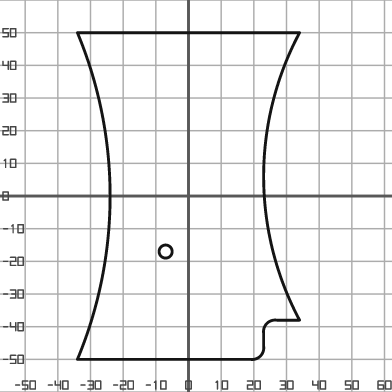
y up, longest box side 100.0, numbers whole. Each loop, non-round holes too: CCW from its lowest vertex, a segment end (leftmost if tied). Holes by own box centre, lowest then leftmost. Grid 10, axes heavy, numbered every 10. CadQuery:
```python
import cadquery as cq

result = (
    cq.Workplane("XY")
    .moveTo(-34.0, -50.0)
    .lineTo(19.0, -50.0)
    .threePointArc((22.0, -49.0), (23.0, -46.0))
    .lineTo(23.0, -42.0)
    .threePointArc((24.0, -39.0), (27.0, -38.0))
    .lineTo(34.0, -38.0)
    .threePointArc((23.0, 6.0), (34.0, 50.0))
    .lineTo(-34.0, 50.0)
    .threePointArc((-24.0, 0.0), (-34.0, -50.0))
    .close()
    .moveTo(-7.0, -17.0)
    .circle(2.0)
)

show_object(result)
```